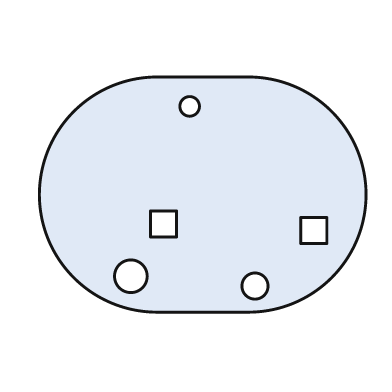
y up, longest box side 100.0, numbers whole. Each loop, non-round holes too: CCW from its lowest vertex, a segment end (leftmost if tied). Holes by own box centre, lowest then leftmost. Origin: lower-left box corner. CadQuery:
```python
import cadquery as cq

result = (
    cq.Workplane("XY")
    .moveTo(36.0, 0.0)
    .lineTo(64.0, 0.0)
    .threePointArc((100.0, 36.0), (64.0, 72.0))
    .lineTo(36.0, 72.0)
    .threePointArc((0.0, 36.0), (36.0, 0.0))
    .close()
    .moveTo(66.0, 8.0)
    .circle(4.0)
    .moveTo(28.0, 11.0)
    .circle(5.0)
    .moveTo(80.0, 21.0)
    .lineTo(88.0, 21.0)
    .lineTo(88.0, 29.0)
    .lineTo(80.0, 29.0)
    .close()
    .moveTo(34.0, 23.0)
    .lineTo(42.0, 23.0)
    .lineTo(42.0, 31.0)
    .lineTo(34.0, 31.0)
    .close()
    .moveTo(46.0, 63.0)
    .circle(3.0)
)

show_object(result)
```